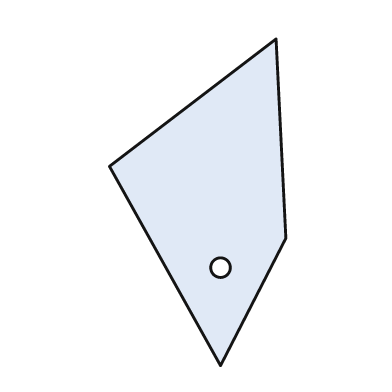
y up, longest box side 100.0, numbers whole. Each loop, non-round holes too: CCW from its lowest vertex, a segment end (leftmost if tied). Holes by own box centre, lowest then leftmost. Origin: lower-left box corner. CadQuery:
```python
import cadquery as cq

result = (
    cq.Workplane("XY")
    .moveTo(34.0, 0.0)
    .lineTo(54.0, 39.0)
    .lineTo(51.0, 100.0)
    .lineTo(0.0, 61.0)
    .close()
    .moveTo(34.0, 30.0)
    .circle(3.0)
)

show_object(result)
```